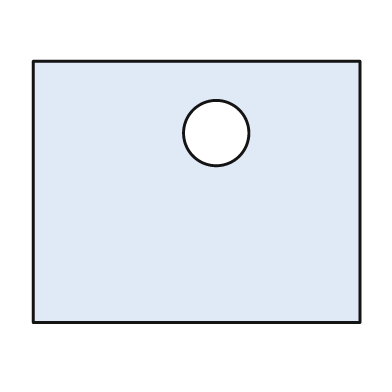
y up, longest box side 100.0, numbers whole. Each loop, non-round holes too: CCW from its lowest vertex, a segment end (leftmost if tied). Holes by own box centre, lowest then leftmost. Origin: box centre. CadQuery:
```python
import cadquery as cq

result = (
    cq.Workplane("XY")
    .moveTo(-50.0, -40.0)
    .lineTo(50.0, -40.0)
    .lineTo(50.0, 40.0)
    .lineTo(-50.0, 40.0)
    .close()
    .moveTo(6.0, 18.0)
    .circle(10.0)
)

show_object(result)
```